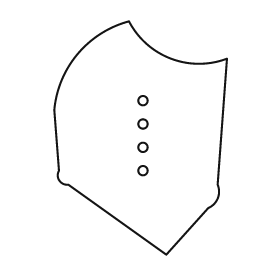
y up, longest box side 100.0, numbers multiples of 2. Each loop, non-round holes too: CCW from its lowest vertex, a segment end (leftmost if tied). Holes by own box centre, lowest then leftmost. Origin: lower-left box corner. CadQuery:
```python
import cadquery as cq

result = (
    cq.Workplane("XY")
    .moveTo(48.0, 0.0)
    .lineTo(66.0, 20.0)
    .threePointArc((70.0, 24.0), (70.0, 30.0))
    .lineTo(74.0, 84.0)
    .threePointArc((50.0, 84.0), (32.0, 100.0))
    .threePointArc((10.0, 86.0), (0.0, 62.0))
    .lineTo(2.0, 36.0)
    .threePointArc((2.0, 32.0), (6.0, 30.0))
    .close()
    .moveTo(38.0, 36.0)
    .circle(2.0)
    .moveTo(38.0, 46.0)
    .circle(2.0)
    .moveTo(38.0, 56.0)
    .circle(2.0)
    .moveTo(38.0, 66.0)
    .circle(2.0)
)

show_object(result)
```